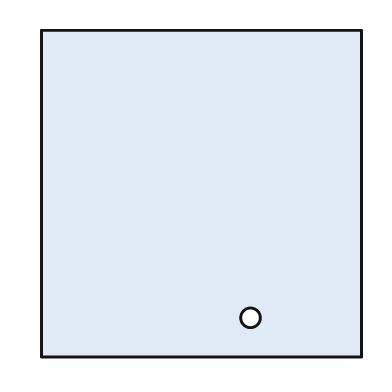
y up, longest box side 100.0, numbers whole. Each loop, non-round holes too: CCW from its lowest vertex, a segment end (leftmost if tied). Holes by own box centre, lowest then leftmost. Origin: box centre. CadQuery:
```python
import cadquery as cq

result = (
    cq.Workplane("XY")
    .moveTo(-49.0, -50.0)
    .lineTo(49.0, -50.0)
    .lineTo(49.0, 50.0)
    .lineTo(-49.0, 50.0)
    .close()
    .moveTo(15.0, -38.0)
    .circle(3.0)
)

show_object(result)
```